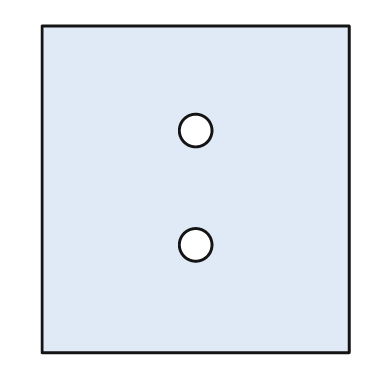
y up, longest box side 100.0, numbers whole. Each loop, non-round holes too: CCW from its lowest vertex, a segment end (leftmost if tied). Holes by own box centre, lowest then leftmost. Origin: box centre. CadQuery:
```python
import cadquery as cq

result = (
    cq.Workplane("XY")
    .moveTo(-47.0, -50.0)
    .lineTo(47.0, -50.0)
    .lineTo(47.0, 50.0)
    .lineTo(-47.0, 50.0)
    .close()
    .moveTo(0.0, -17.0)
    .circle(5.0)
    .moveTo(0.0, 18.0)
    .circle(5.0)
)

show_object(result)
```